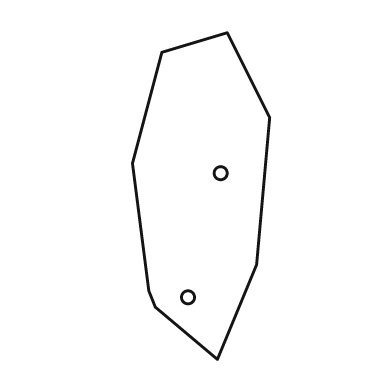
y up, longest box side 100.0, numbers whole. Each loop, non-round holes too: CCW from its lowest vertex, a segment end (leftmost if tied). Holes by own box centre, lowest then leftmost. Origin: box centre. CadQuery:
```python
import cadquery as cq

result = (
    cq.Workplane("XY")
    .moveTo(5.0, -50.0)
    .lineTo(17.0, -21.0)
    .lineTo(21.0, 24.0)
    .lineTo(8.0, 50.0)
    .lineTo(-12.0, 44.0)
    .lineTo(-21.0, 10.0)
    .lineTo(-16.0, -29.0)
    .lineTo(-14.0, -34.0)
    .close()
    .moveTo(-4.0, -31.0)
    .circle(2.0)
    .moveTo(6.0, 7.0)
    .circle(2.0)
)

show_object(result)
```